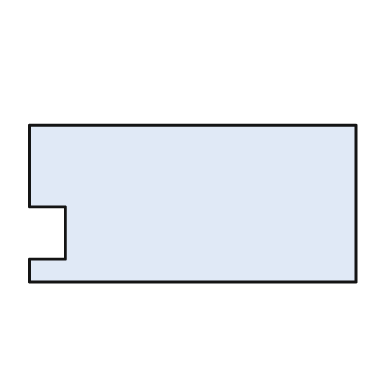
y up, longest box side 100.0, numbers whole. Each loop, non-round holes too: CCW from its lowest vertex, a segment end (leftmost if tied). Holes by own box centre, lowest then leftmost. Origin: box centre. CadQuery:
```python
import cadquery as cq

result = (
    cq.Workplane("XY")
    .moveTo(-50.0, -24.0)
    .lineTo(50.0, -24.0)
    .lineTo(50.0, 24.0)
    .lineTo(-50.0, 24.0)
    .lineTo(-50.0, -1.0)
    .lineTo(-39.0, -1.0)
    .lineTo(-39.0, -17.0)
    .lineTo(-50.0, -17.0)
    .close()
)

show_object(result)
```